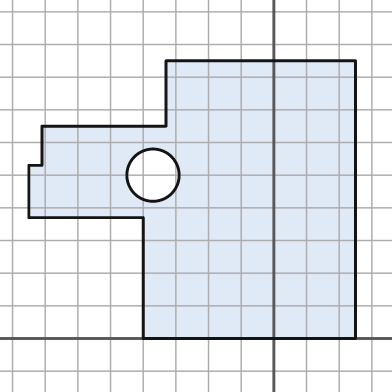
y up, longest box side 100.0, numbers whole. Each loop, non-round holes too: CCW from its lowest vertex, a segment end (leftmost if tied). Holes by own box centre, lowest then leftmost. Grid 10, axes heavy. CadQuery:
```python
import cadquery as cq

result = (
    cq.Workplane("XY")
    .moveTo(-40.0, 0.0)
    .lineTo(25.0, 0.0)
    .lineTo(25.0, 85.0)
    .lineTo(-33.0, 85.0)
    .lineTo(-33.0, 65.0)
    .lineTo(-71.0, 65.0)
    .lineTo(-71.0, 53.0)
    .lineTo(-75.0, 53.0)
    .lineTo(-75.0, 37.0)
    .lineTo(-40.0, 37.0)
    .close()
    .moveTo(-37.0, 50.0)
    .circle(8.0)
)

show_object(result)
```